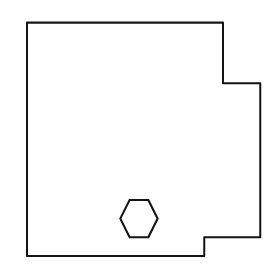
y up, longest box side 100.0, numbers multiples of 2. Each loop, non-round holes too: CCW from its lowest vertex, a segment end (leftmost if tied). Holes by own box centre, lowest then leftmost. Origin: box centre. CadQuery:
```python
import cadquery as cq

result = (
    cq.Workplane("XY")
    .moveTo(-50.0, -50.0)
    .lineTo(26.0, -50.0)
    .lineTo(26.0, -42.0)
    .lineTo(50.0, -42.0)
    .lineTo(50.0, 24.0)
    .lineTo(34.0, 24.0)
    .lineTo(34.0, 50.0)
    .lineTo(-50.0, 50.0)
    .close()
    .moveTo(-6.0, -42.0)
    .lineTo(2.0, -42.0)
    .lineTo(6.0, -34.0)
    .lineTo(2.0, -26.0)
    .lineTo(-6.0, -26.0)
    .lineTo(-10.0, -34.0)
    .close()
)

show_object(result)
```